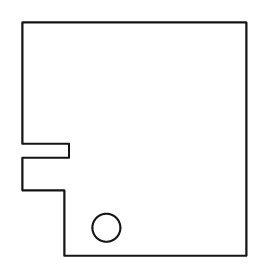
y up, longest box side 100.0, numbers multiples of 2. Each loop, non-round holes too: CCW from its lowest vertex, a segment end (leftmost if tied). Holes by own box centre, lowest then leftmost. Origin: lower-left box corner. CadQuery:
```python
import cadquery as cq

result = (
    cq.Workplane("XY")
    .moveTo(18.0, 0.0)
    .lineTo(96.0, 0.0)
    .lineTo(96.0, 100.0)
    .lineTo(0.0, 100.0)
    .lineTo(0.0, 48.0)
    .lineTo(20.0, 48.0)
    .lineTo(20.0, 42.0)
    .lineTo(0.0, 42.0)
    .lineTo(0.0, 28.0)
    .lineTo(18.0, 28.0)
    .close()
    .moveTo(36.0, 12.0)
    .circle(6.0)
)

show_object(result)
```